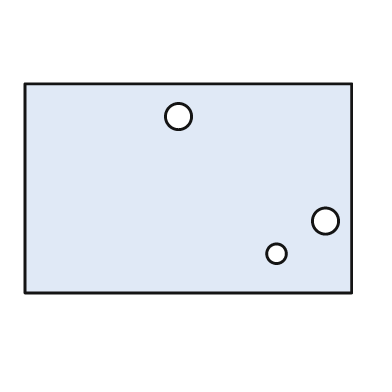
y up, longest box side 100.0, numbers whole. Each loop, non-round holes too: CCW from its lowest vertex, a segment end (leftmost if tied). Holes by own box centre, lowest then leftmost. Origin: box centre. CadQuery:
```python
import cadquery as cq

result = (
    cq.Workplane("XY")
    .moveTo(-50.0, -32.0)
    .lineTo(50.0, -32.0)
    .lineTo(50.0, 32.0)
    .lineTo(-50.0, 32.0)
    .close()
    .moveTo(27.0, -20.0)
    .circle(3.0)
    .moveTo(42.0, -10.0)
    .circle(4.0)
    .moveTo(-3.0, 22.0)
    .circle(4.0)
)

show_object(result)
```